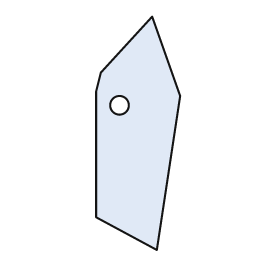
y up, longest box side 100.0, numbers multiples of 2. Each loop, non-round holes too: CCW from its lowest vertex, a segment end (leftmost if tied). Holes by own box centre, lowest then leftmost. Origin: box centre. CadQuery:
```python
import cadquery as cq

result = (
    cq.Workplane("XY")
    .moveTo(8.0, -50.0)
    .lineTo(18.0, 16.0)
    .lineTo(6.0, 50.0)
    .lineTo(-16.0, 26.0)
    .lineTo(-18.0, 18.0)
    .lineTo(-18.0, -36.0)
    .close()
    .moveTo(-8.0, 12.0)
    .circle(4.0)
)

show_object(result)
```